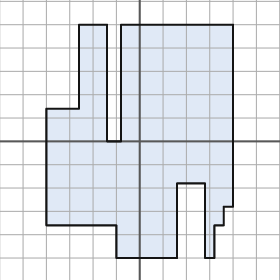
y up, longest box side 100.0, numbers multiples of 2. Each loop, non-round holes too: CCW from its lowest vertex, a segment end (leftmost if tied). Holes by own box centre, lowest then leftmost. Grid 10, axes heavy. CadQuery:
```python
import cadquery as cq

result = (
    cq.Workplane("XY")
    .moveTo(-10.0, -50.0)
    .lineTo(16.0, -50.0)
    .lineTo(16.0, -18.0)
    .lineTo(28.0, -18.0)
    .lineTo(28.0, -50.0)
    .lineTo(32.0, -50.0)
    .lineTo(32.0, -36.0)
    .lineTo(36.0, -36.0)
    .lineTo(36.0, -28.0)
    .lineTo(40.0, -28.0)
    .lineTo(40.0, 50.0)
    .lineTo(-8.0, 50.0)
    .lineTo(-8.0, 0.0)
    .lineTo(-14.0, 0.0)
    .lineTo(-14.0, 50.0)
    .lineTo(-26.0, 50.0)
    .lineTo(-26.0, 14.0)
    .lineTo(-40.0, 14.0)
    .lineTo(-40.0, -36.0)
    .lineTo(-10.0, -36.0)
    .close()
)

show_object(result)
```